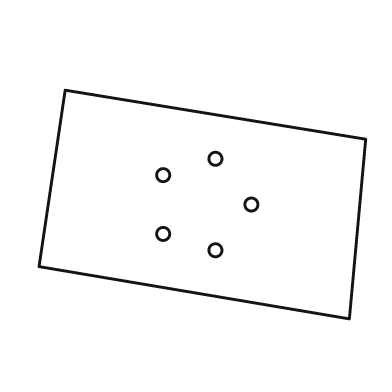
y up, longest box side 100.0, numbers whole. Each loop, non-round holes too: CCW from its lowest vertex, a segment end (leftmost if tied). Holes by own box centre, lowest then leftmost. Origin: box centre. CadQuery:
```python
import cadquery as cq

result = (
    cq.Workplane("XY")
    .moveTo(45.0, -35.0)
    .lineTo(50.0, 20.0)
    .lineTo(-42.0, 35.0)
    .lineTo(-50.0, -19.0)
    .close()
    .moveTo(4.0, -14.0)
    .circle(2.0)
    .moveTo(-12.0, -9.0)
    .circle(2.0)
    .moveTo(15.0, 0.0)
    .circle(2.0)
    .moveTo(-12.0, 9.0)
    .circle(2.0)
    .moveTo(4.0, 14.0)
    .circle(2.0)
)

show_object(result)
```